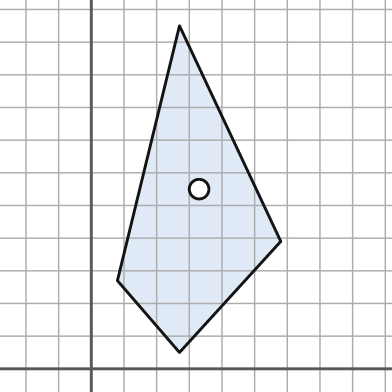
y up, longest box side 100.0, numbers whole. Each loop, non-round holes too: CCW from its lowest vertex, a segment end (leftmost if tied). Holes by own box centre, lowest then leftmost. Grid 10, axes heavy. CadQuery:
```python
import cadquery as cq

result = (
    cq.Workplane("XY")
    .moveTo(27.0, 5.0)
    .lineTo(58.0, 39.0)
    .lineTo(27.0, 105.0)
    .lineTo(8.0, 27.0)
    .close()
    .moveTo(33.0, 55.0)
    .circle(3.0)
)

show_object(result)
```